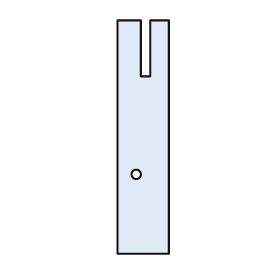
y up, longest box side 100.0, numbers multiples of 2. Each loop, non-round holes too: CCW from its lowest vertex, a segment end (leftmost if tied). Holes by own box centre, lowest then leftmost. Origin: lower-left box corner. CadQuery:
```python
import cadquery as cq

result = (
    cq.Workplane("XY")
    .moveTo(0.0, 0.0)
    .lineTo(22.0, 0.0)
    .lineTo(22.0, 100.0)
    .lineTo(14.0, 100.0)
    .lineTo(14.0, 76.0)
    .lineTo(10.0, 76.0)
    .lineTo(10.0, 100.0)
    .lineTo(0.0, 100.0)
    .close()
    .moveTo(8.0, 34.0)
    .circle(2.0)
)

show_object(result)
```